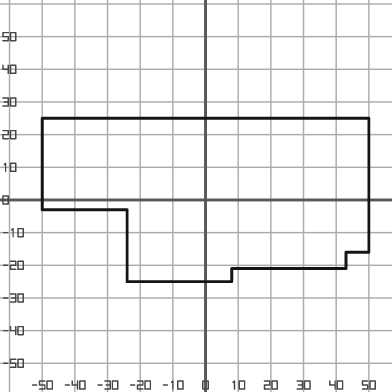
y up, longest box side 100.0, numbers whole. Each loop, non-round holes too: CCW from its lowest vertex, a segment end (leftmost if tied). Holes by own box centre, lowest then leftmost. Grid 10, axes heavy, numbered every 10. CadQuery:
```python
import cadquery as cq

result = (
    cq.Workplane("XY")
    .moveTo(-24.0, -25.0)
    .lineTo(8.0, -25.0)
    .lineTo(8.0, -21.0)
    .lineTo(43.0, -21.0)
    .lineTo(43.0, -16.0)
    .lineTo(50.0, -16.0)
    .lineTo(50.0, 25.0)
    .lineTo(-50.0, 25.0)
    .lineTo(-50.0, -3.0)
    .lineTo(-24.0, -3.0)
    .close()
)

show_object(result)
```